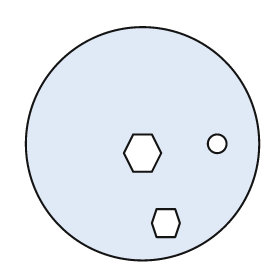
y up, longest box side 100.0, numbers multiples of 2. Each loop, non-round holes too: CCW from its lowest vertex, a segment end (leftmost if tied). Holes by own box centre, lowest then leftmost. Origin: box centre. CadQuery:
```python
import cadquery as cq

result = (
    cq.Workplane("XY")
    .moveTo(0.0, 0.0)
    .circle(50.0)
    .moveTo(6.0, -40.0)
    .lineTo(14.0, -40.0)
    .lineTo(16.0, -34.0)
    .lineTo(14.0, -28.0)
    .lineTo(6.0, -28.0)
    .lineTo(4.0, -34.0)
    .close()
    .moveTo(-4.0, -12.0)
    .lineTo(4.0, -12.0)
    .lineTo(8.0, -4.0)
    .lineTo(4.0, 4.0)
    .lineTo(-4.0, 4.0)
    .lineTo(-8.0, -4.0)
    .close()
    .moveTo(32.0, 0.0)
    .circle(4.0)
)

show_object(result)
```